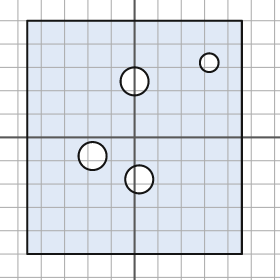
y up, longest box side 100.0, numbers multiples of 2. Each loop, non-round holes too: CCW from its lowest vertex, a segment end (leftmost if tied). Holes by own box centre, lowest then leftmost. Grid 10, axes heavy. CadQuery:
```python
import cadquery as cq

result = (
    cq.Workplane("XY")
    .moveTo(-46.0, -50.0)
    .lineTo(46.0, -50.0)
    .lineTo(46.0, 50.0)
    .lineTo(-46.0, 50.0)
    .close()
    .moveTo(2.0, -18.0)
    .circle(6.0)
    .moveTo(-18.0, -8.0)
    .circle(6.0)
    .moveTo(0.0, 24.0)
    .circle(6.0)
    .moveTo(32.0, 32.0)
    .circle(4.0)
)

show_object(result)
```